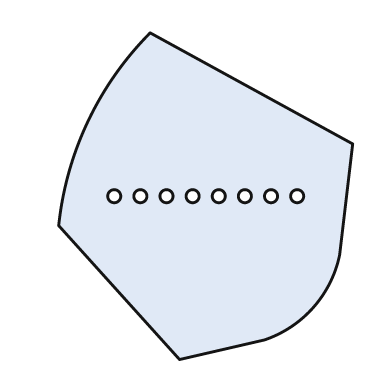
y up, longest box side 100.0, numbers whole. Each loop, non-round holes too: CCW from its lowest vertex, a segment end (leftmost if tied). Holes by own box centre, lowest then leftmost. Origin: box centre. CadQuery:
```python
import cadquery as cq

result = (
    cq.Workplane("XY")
    .moveTo(-8.0, -50.0)
    .lineTo(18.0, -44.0)
    .threePointArc((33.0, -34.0), (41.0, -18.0))
    .lineTo(45.0, 16.0)
    .lineTo(-17.0, 50.0)
    .threePointArc((-36.0, 23.0), (-45.0, -9.0))
    .close()
    .moveTo(-28.0, 0.0)
    .circle(2.0)
    .moveTo(-20.0, 0.0)
    .circle(2.0)
    .moveTo(-12.0, 0.0)
    .circle(2.0)
    .moveTo(-4.0, 0.0)
    .circle(2.0)
    .moveTo(4.0, 0.0)
    .circle(2.0)
    .moveTo(12.0, 0.0)
    .circle(2.0)
    .moveTo(20.0, 0.0)
    .circle(2.0)
    .moveTo(28.0, 0.0)
    .circle(2.0)
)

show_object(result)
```